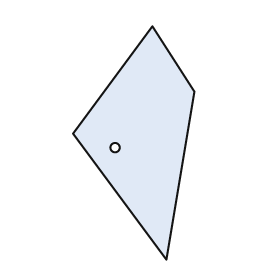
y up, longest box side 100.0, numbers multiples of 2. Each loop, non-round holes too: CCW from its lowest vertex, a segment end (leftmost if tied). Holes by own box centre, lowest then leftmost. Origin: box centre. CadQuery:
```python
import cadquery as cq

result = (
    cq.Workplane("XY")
    .moveTo(14.0, -50.0)
    .lineTo(26.0, 22.0)
    .lineTo(8.0, 50.0)
    .lineTo(-26.0, 4.0)
    .close()
    .moveTo(-8.0, -2.0)
    .circle(2.0)
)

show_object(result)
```